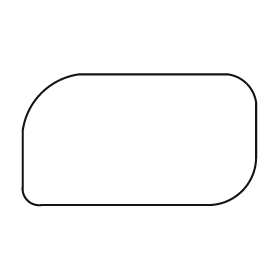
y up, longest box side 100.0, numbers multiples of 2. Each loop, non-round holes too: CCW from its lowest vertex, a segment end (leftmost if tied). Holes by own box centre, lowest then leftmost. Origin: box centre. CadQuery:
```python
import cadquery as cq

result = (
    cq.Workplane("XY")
    .moveTo(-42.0, -28.0)
    .lineTo(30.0, -28.0)
    .threePointArc((44.0, -22.0), (50.0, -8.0))
    .lineTo(50.0, 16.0)
    .threePointArc((46.0, 24.0), (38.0, 28.0))
    .lineTo(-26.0, 28.0)
    .threePointArc((-42.0, 20.0), (-50.0, 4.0))
    .lineTo(-50.0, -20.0)
    .threePointArc((-48.0, -26.0), (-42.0, -28.0))
    .close()
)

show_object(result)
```